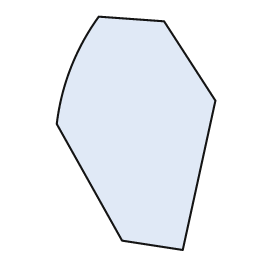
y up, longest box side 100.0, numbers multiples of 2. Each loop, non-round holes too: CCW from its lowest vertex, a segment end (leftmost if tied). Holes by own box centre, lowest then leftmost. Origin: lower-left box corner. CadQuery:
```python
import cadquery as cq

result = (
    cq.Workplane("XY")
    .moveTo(54.0, 0.0)
    .lineTo(68.0, 64.0)
    .lineTo(46.0, 98.0)
    .lineTo(18.0, 100.0)
    .threePointArc((6.0, 78.0), (0.0, 54.0))
    .lineTo(28.0, 4.0)
    .close()
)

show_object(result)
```